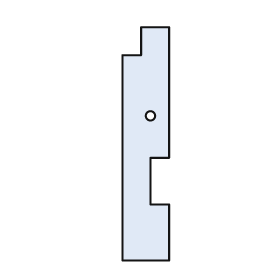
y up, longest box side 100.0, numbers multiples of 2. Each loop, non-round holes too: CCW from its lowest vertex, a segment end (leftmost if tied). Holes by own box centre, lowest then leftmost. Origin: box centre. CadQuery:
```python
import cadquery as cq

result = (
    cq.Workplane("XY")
    .moveTo(-10.0, -50.0)
    .lineTo(10.0, -50.0)
    .lineTo(10.0, -26.0)
    .lineTo(2.0, -26.0)
    .lineTo(2.0, -6.0)
    .lineTo(10.0, -6.0)
    .lineTo(10.0, 50.0)
    .lineTo(-2.0, 50.0)
    .lineTo(-2.0, 38.0)
    .lineTo(-10.0, 38.0)
    .close()
    .moveTo(2.0, 12.0)
    .circle(2.0)
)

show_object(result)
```